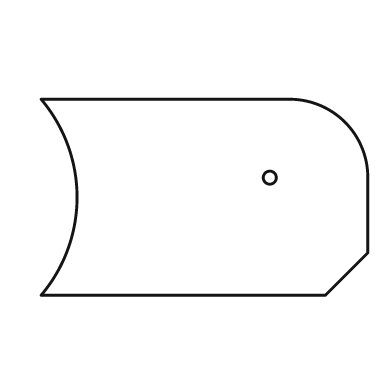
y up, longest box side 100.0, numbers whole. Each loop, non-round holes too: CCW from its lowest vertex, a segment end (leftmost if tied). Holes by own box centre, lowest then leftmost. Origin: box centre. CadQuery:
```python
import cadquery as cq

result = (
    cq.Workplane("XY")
    .moveTo(-50.0, -30.0)
    .lineTo(37.0, -30.0)
    .lineTo(50.0, -17.0)
    .lineTo(50.0, 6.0)
    .threePointArc((43.0, 23.0), (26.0, 30.0))
    .lineTo(-50.0, 30.0)
    .threePointArc((-39.0, 0.0), (-50.0, -30.0))
    .close()
    .moveTo(20.0, 6.0)
    .circle(2.0)
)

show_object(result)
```